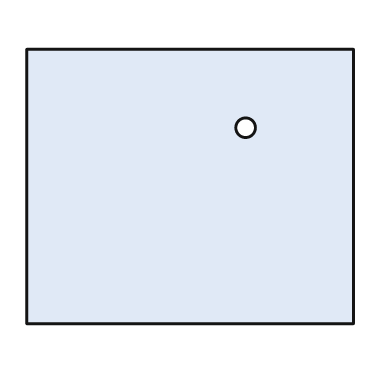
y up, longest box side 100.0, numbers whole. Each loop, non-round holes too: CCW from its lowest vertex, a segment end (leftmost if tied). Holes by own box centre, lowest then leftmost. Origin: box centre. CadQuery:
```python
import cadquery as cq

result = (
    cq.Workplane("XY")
    .moveTo(-50.0, -42.0)
    .lineTo(50.0, -42.0)
    .lineTo(50.0, 42.0)
    .lineTo(-50.0, 42.0)
    .close()
    .moveTo(17.0, 18.0)
    .circle(3.0)
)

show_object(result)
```